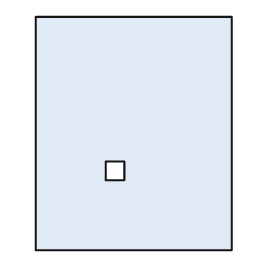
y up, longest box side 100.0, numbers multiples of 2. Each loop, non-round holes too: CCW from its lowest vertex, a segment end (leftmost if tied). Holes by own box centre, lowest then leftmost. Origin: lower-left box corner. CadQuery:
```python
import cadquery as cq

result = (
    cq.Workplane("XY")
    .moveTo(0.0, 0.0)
    .lineTo(84.0, 0.0)
    .lineTo(84.0, 100.0)
    .lineTo(0.0, 100.0)
    .close()
    .moveTo(30.0, 30.0)
    .lineTo(38.0, 30.0)
    .lineTo(38.0, 38.0)
    .lineTo(30.0, 38.0)
    .close()
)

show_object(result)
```